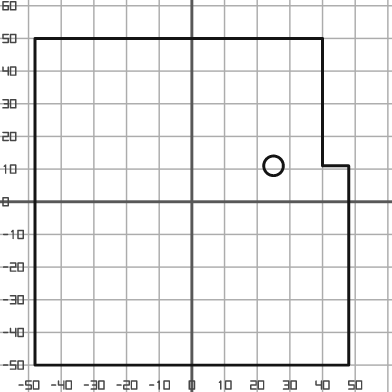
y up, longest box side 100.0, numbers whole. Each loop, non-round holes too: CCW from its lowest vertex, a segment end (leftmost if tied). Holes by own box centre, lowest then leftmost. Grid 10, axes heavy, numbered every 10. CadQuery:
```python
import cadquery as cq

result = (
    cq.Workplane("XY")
    .moveTo(-48.0, -50.0)
    .lineTo(48.0, -50.0)
    .lineTo(48.0, 11.0)
    .lineTo(40.0, 11.0)
    .lineTo(40.0, 50.0)
    .lineTo(-48.0, 50.0)
    .close()
    .moveTo(25.0, 11.0)
    .circle(3.0)
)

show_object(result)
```